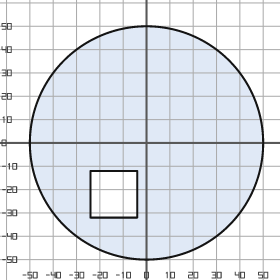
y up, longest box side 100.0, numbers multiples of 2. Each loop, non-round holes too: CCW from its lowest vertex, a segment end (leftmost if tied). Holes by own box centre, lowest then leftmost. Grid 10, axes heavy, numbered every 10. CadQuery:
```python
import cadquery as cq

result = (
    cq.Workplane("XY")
    .moveTo(0.0, 0.0)
    .circle(50.0)
    .moveTo(-24.0, -32.0)
    .lineTo(-4.0, -32.0)
    .lineTo(-4.0, -12.0)
    .lineTo(-24.0, -12.0)
    .close()
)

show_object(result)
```